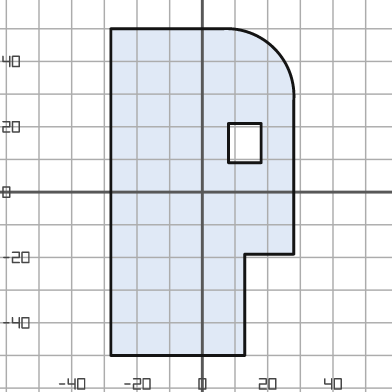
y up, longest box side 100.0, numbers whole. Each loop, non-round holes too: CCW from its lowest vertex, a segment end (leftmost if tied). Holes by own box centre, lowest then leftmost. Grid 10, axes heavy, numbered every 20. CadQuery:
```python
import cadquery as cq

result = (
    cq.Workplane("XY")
    .moveTo(-28.0, -50.0)
    .lineTo(13.0, -50.0)
    .lineTo(13.0, -19.0)
    .lineTo(28.0, -19.0)
    .lineTo(28.0, 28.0)
    .threePointArc((22.0, 44.0), (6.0, 50.0))
    .lineTo(-28.0, 50.0)
    .close()
    .moveTo(8.0, 9.0)
    .lineTo(18.0, 9.0)
    .lineTo(18.0, 21.0)
    .lineTo(8.0, 21.0)
    .close()
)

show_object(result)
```